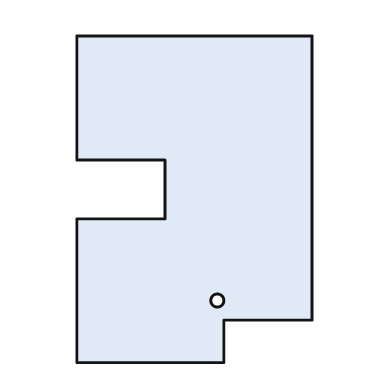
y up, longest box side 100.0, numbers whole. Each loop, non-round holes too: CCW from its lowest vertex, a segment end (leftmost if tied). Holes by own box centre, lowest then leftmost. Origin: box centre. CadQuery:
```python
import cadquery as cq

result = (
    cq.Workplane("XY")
    .moveTo(-36.0, -50.0)
    .lineTo(9.0, -50.0)
    .lineTo(9.0, -37.0)
    .lineTo(36.0, -37.0)
    .lineTo(36.0, 50.0)
    .lineTo(-36.0, 50.0)
    .lineTo(-36.0, 12.0)
    .lineTo(-9.0, 12.0)
    .lineTo(-9.0, -6.0)
    .lineTo(-36.0, -6.0)
    .close()
    .moveTo(7.0, -31.0)
    .circle(2.0)
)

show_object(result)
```